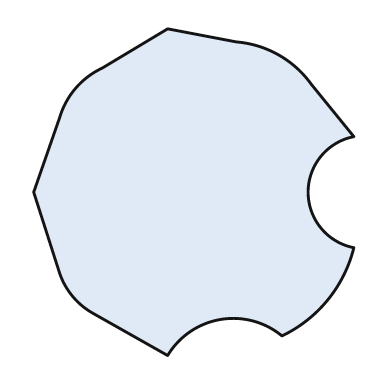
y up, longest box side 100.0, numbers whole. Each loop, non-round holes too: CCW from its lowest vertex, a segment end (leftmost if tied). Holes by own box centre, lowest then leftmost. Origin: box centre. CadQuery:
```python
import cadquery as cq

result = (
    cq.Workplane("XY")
    .moveTo(-8.0, -50.0)
    .threePointArc((8.0, -39.0), (27.0, -44.0))
    .threePointArc((41.0, -33.0), (49.0, -17.0))
    .threePointArc((35.0, 0.0), (49.0, 17.0))
    .lineTo(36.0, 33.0)
    .threePointArc((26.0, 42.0), (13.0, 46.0))
    .lineTo(-8.0, 50.0)
    .lineTo(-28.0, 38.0)
    .threePointArc((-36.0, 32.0), (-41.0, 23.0))
    .lineTo(-49.0, 0.0)
    .lineTo(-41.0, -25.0)
    .threePointArc((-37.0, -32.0), (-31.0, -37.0))
    .close()
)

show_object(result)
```